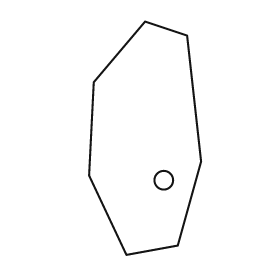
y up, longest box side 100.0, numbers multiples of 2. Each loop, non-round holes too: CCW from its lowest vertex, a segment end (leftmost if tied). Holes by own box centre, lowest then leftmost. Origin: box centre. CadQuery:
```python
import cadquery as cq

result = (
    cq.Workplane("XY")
    .moveTo(-8.0, -50.0)
    .lineTo(14.0, -46.0)
    .lineTo(24.0, -10.0)
    .lineTo(18.0, 44.0)
    .lineTo(0.0, 50.0)
    .lineTo(-22.0, 24.0)
    .lineTo(-24.0, -16.0)
    .close()
    .moveTo(8.0, -18.0)
    .circle(4.0)
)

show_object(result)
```